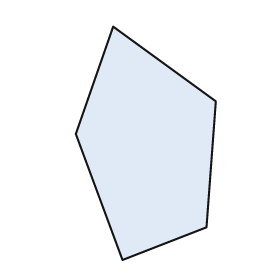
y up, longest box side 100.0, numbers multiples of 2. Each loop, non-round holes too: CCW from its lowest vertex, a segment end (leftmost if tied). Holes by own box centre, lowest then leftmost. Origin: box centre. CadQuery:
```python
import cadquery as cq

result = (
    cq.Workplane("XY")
    .moveTo(-10.0, -50.0)
    .lineTo(26.0, -36.0)
    .lineTo(30.0, 18.0)
    .lineTo(-14.0, 50.0)
    .lineTo(-30.0, 4.0)
    .close()
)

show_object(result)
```